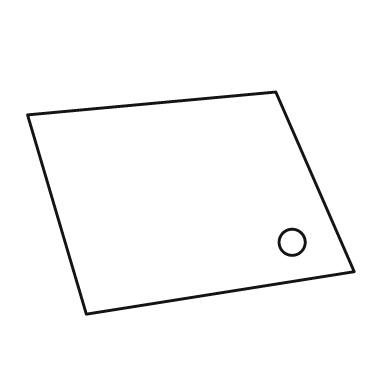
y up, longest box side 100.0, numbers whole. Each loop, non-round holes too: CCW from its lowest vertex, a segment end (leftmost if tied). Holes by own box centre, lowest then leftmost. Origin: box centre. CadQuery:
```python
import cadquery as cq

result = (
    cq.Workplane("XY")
    .moveTo(-32.0, -34.0)
    .lineTo(50.0, -21.0)
    .lineTo(26.0, 34.0)
    .lineTo(-50.0, 27.0)
    .close()
    .moveTo(31.0, -12.0)
    .circle(4.0)
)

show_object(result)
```